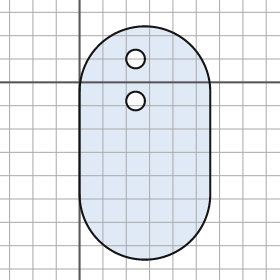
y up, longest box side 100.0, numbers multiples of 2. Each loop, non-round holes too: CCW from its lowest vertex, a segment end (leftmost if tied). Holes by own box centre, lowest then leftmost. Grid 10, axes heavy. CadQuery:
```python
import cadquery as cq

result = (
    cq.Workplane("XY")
    .moveTo(0.0, -48.0)
    .threePointArc((28.0, -76.0), (56.0, -48.0))
    .lineTo(56.0, -4.0)
    .threePointArc((28.0, 24.0), (0.0, -4.0))
    .close()
    .moveTo(24.0, -8.0)
    .circle(4.0)
    .moveTo(24.0, 10.0)
    .circle(4.0)
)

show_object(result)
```